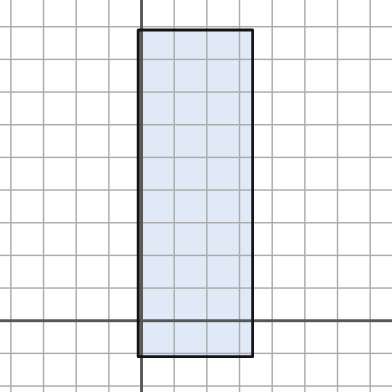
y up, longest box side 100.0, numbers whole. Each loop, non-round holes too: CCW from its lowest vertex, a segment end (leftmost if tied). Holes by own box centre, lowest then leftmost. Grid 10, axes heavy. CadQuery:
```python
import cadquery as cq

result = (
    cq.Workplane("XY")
    .moveTo(-1.0, -11.0)
    .lineTo(34.0, -11.0)
    .lineTo(34.0, 89.0)
    .lineTo(-1.0, 89.0)
    .close()
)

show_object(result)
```